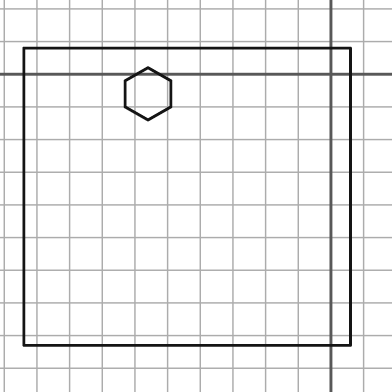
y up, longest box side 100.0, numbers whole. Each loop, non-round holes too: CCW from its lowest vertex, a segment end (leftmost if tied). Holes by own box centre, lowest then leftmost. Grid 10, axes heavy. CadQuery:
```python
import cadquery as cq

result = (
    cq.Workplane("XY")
    .moveTo(-94.0, -83.0)
    .lineTo(6.0, -83.0)
    .lineTo(6.0, 8.0)
    .lineTo(-94.0, 8.0)
    .close()
    .moveTo(-56.0, -14.0)
    .lineTo(-49.0, -10.0)
    .lineTo(-49.0, -2.0)
    .lineTo(-56.0, 2.0)
    .lineTo(-63.0, -2.0)
    .lineTo(-63.0, -10.0)
    .close()
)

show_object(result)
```